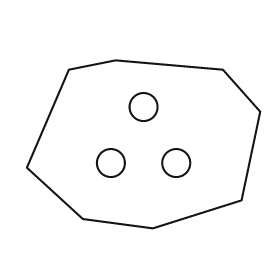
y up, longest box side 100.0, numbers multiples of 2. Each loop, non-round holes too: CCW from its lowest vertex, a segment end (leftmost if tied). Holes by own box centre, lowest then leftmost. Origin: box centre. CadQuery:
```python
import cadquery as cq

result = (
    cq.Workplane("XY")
    .moveTo(4.0, -36.0)
    .lineTo(42.0, -24.0)
    .lineTo(50.0, 14.0)
    .lineTo(34.0, 32.0)
    .lineTo(-12.0, 36.0)
    .lineTo(-32.0, 32.0)
    .lineTo(-50.0, -10.0)
    .lineTo(-26.0, -32.0)
    .close()
    .moveTo(-14.0, -8.0)
    .circle(6.0)
    .moveTo(14.0, -8.0)
    .circle(6.0)
    .moveTo(0.0, 16.0)
    .circle(6.0)
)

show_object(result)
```